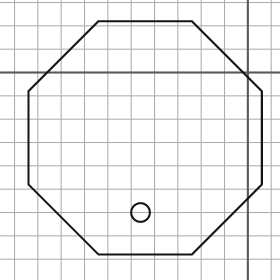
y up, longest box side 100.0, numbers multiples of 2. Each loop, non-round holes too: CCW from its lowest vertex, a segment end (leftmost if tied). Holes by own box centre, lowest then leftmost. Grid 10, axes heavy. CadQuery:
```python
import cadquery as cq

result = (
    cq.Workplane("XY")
    .moveTo(-64.0, -78.0)
    .lineTo(-24.0, -78.0)
    .lineTo(6.0, -48.0)
    .lineTo(6.0, -8.0)
    .lineTo(-24.0, 22.0)
    .lineTo(-64.0, 22.0)
    .lineTo(-94.0, -8.0)
    .lineTo(-94.0, -48.0)
    .close()
    .moveTo(-46.0, -60.0)
    .circle(4.0)
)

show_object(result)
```